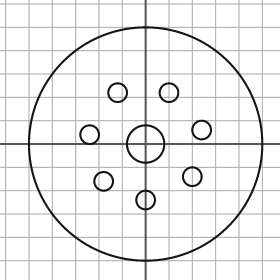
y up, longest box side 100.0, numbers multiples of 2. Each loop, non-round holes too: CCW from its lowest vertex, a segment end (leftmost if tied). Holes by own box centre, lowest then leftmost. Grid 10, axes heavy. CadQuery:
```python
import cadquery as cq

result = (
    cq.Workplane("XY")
    .moveTo(0.0, 0.0)
    .circle(50.0)
    .moveTo(0.0, -24.0)
    .circle(4.0)
    .moveTo(-18.0, -16.0)
    .circle(4.0)
    .moveTo(20.0, -14.0)
    .circle(4.0)
    .moveTo(0.0, 0.0)
    .circle(8.0)
    .moveTo(-24.0, 4.0)
    .circle(4.0)
    .moveTo(24.0, 6.0)
    .circle(4.0)
    .moveTo(-12.0, 22.0)
    .circle(4.0)
    .moveTo(10.0, 22.0)
    .circle(4.0)
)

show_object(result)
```